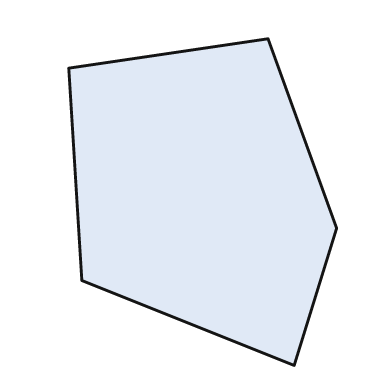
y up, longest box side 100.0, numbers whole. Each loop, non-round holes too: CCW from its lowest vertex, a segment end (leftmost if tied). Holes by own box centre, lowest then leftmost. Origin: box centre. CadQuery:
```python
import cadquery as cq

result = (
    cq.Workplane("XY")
    .moveTo(28.0, -50.0)
    .lineTo(41.0, -8.0)
    .lineTo(20.0, 50.0)
    .lineTo(-41.0, 41.0)
    .lineTo(-37.0, -24.0)
    .close()
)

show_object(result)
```